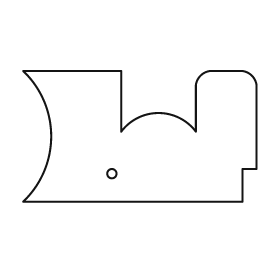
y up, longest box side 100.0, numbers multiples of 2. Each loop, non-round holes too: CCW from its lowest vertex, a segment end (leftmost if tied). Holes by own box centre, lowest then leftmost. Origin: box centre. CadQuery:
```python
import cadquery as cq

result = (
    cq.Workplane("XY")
    .moveTo(-50.0, -28.0)
    .lineTo(44.0, -28.0)
    .lineTo(44.0, -14.0)
    .lineTo(50.0, -14.0)
    .lineTo(50.0, 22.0)
    .threePointArc((48.0, 26.0), (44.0, 28.0))
    .lineTo(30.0, 28.0)
    .threePointArc((26.0, 26.0), (24.0, 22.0))
    .lineTo(24.0, 2.0)
    .threePointArc((8.0, 10.0), (-8.0, 2.0))
    .lineTo(-8.0, 28.0)
    .lineTo(-50.0, 28.0)
    .threePointArc((-38.0, 0.0), (-50.0, -28.0))
    .close()
    .moveTo(-12.0, -16.0)
    .circle(2.0)
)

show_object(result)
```